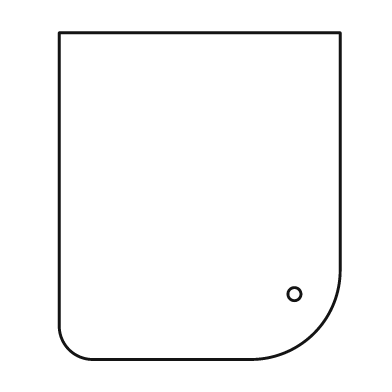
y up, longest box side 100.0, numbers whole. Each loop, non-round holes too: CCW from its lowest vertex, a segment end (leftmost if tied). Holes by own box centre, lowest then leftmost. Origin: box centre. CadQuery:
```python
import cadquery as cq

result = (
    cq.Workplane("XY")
    .moveTo(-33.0, -50.0)
    .lineTo(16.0, -50.0)
    .threePointArc((35.0, -42.0), (43.0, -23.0))
    .lineTo(43.0, 50.0)
    .lineTo(-43.0, 50.0)
    .lineTo(-43.0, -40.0)
    .threePointArc((-40.0, -47.0), (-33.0, -50.0))
    .close()
    .moveTo(29.0, -30.0)
    .circle(2.0)
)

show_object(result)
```